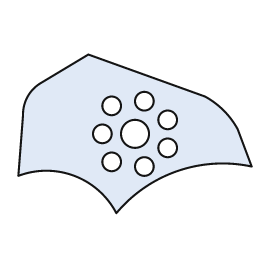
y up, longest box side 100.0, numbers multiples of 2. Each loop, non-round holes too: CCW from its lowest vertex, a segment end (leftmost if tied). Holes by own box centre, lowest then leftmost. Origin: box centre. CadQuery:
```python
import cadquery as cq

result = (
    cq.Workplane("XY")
    .moveTo(-8.0, -34.0)
    .threePointArc((18.0, -16.0), (50.0, -14.0))
    .lineTo(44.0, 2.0)
    .threePointArc((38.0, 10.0), (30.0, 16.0))
    .lineTo(-20.0, 34.0)
    .lineTo(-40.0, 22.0)
    .threePointArc((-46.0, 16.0), (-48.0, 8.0))
    .lineTo(-50.0, -18.0)
    .threePointArc((-26.0, -18.0), (-8.0, -34.0))
    .close()
    .moveTo(4.0, -14.0)
    .circle(4.0)
    .moveTo(-10.0, -12.0)
    .circle(4.0)
    .moveTo(14.0, -6.0)
    .circle(4.0)
    .moveTo(-14.0, 0.0)
    .circle(4.0)
    .moveTo(0.0, 0.0)
    .circle(6.0)
    .moveTo(14.0, 6.0)
    .circle(4.0)
    .moveTo(-10.0, 12.0)
    .circle(4.0)
    .moveTo(4.0, 14.0)
    .circle(4.0)
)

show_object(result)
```